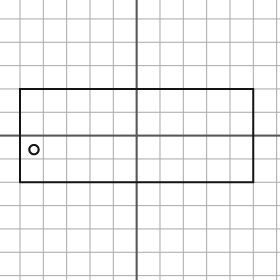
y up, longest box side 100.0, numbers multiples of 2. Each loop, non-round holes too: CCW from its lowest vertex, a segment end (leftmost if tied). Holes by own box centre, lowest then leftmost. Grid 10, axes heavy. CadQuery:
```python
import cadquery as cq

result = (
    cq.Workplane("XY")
    .moveTo(-50.0, -20.0)
    .lineTo(50.0, -20.0)
    .lineTo(50.0, 20.0)
    .lineTo(-50.0, 20.0)
    .close()
    .moveTo(-44.0, -6.0)
    .circle(2.0)
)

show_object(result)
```